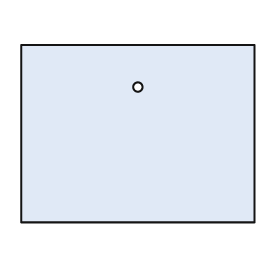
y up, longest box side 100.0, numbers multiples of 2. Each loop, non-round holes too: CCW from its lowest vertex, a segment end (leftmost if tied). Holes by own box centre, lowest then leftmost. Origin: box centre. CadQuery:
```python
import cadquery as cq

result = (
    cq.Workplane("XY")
    .moveTo(-50.0, -38.0)
    .lineTo(50.0, -38.0)
    .lineTo(50.0, 38.0)
    .lineTo(-50.0, 38.0)
    .close()
    .moveTo(0.0, 20.0)
    .circle(2.0)
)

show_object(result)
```